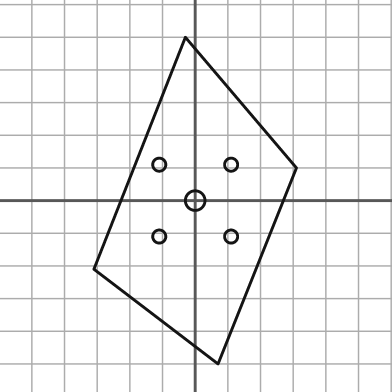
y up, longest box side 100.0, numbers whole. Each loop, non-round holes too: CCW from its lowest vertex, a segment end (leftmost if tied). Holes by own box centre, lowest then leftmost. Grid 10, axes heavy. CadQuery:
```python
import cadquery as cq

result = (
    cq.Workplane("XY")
    .moveTo(7.0, -50.0)
    .lineTo(31.0, 10.0)
    .lineTo(-3.0, 50.0)
    .lineTo(-31.0, -21.0)
    .close()
    .moveTo(-11.0, -11.0)
    .circle(2.0)
    .moveTo(11.0, -11.0)
    .circle(2.0)
    .moveTo(0.0, 0.0)
    .circle(3.0)
    .moveTo(-11.0, 11.0)
    .circle(2.0)
    .moveTo(11.0, 11.0)
    .circle(2.0)
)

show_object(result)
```